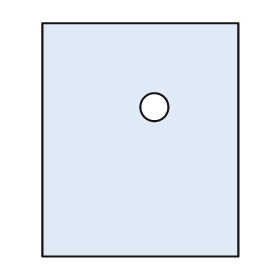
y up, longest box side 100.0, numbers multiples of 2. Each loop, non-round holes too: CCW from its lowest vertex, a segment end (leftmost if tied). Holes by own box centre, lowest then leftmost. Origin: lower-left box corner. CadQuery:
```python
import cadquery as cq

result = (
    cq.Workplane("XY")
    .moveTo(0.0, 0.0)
    .lineTo(84.0, 0.0)
    .lineTo(84.0, 100.0)
    .lineTo(0.0, 100.0)
    .close()
    .moveTo(48.0, 64.0)
    .circle(6.0)
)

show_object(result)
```